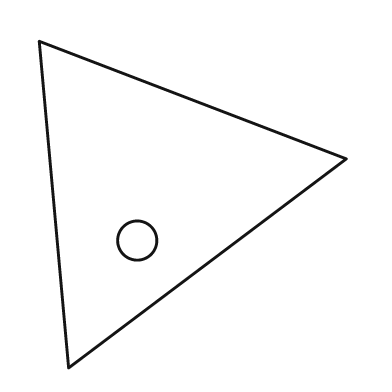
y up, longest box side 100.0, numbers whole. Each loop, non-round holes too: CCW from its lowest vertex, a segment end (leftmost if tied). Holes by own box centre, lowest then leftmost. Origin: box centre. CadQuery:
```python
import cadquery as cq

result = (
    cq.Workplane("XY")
    .moveTo(-38.0, -50.0)
    .lineTo(47.0, 14.0)
    .lineTo(-47.0, 50.0)
    .close()
    .moveTo(-17.0, -11.0)
    .circle(6.0)
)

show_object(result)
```